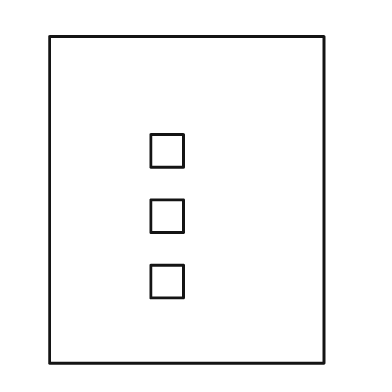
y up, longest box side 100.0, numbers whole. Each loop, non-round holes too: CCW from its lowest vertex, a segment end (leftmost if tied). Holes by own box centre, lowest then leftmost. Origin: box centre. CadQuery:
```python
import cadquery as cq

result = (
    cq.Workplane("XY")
    .moveTo(-42.0, -50.0)
    .lineTo(42.0, -50.0)
    .lineTo(42.0, 50.0)
    .lineTo(-42.0, 50.0)
    .close()
    .moveTo(-11.0, -30.0)
    .lineTo(-1.0, -30.0)
    .lineTo(-1.0, -20.0)
    .lineTo(-11.0, -20.0)
    .close()
    .moveTo(-11.0, -10.0)
    .lineTo(-1.0, -10.0)
    .lineTo(-1.0, 0.0)
    .lineTo(-11.0, 0.0)
    .close()
    .moveTo(-11.0, 10.0)
    .lineTo(-1.0, 10.0)
    .lineTo(-1.0, 20.0)
    .lineTo(-11.0, 20.0)
    .close()
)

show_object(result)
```